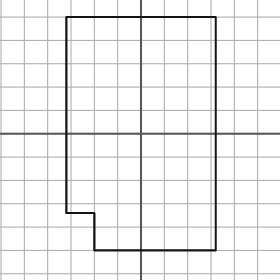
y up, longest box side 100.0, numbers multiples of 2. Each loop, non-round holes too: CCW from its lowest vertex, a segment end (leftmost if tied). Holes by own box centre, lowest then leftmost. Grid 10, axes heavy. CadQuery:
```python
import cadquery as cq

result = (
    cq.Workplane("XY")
    .moveTo(-20.0, -50.0)
    .lineTo(32.0, -50.0)
    .lineTo(32.0, 50.0)
    .lineTo(-32.0, 50.0)
    .lineTo(-32.0, -34.0)
    .lineTo(-20.0, -34.0)
    .close()
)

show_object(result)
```